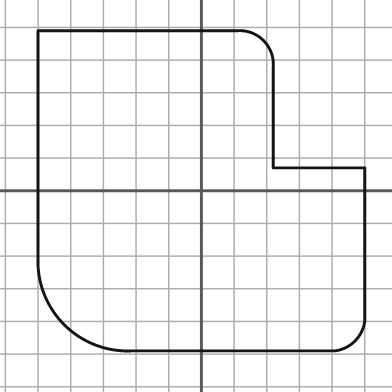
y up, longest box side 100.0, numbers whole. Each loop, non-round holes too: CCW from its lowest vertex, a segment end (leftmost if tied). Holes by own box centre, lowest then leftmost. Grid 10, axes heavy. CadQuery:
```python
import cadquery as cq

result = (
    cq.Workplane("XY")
    .moveTo(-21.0, -49.0)
    .lineTo(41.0, -49.0)
    .threePointArc((47.0, -46.0), (50.0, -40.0))
    .lineTo(50.0, 7.0)
    .lineTo(22.0, 7.0)
    .lineTo(22.0, 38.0)
    .threePointArc((19.0, 46.0), (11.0, 49.0))
    .lineTo(-50.0, 49.0)
    .lineTo(-50.0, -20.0)
    .threePointArc((-42.0, -41.0), (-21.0, -49.0))
    .close()
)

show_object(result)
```